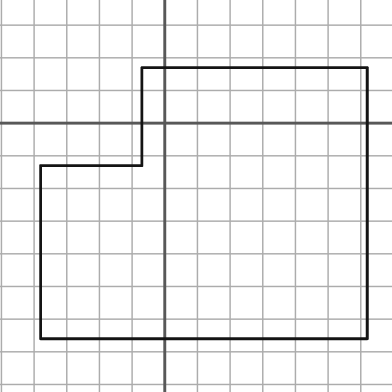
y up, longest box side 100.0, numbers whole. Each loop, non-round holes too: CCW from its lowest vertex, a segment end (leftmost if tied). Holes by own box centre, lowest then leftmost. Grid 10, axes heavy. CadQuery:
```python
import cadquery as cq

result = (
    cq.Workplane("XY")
    .moveTo(-38.0, -66.0)
    .lineTo(62.0, -66.0)
    .lineTo(62.0, 17.0)
    .lineTo(-7.0, 17.0)
    .lineTo(-7.0, -13.0)
    .lineTo(-38.0, -13.0)
    .close()
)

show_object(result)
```